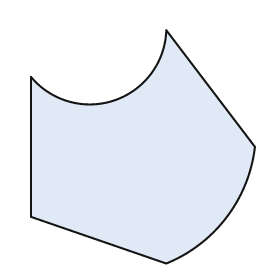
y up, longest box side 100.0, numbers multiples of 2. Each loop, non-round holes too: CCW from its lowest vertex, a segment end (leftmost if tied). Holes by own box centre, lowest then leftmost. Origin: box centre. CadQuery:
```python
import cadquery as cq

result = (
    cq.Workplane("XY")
    .moveTo(10.0, -50.0)
    .threePointArc((36.0, -30.0), (48.0, 0.0))
    .lineTo(10.0, 50.0)
    .threePointArc((-12.0, 20.0), (-48.0, 30.0))
    .lineTo(-48.0, -30.0)
    .close()
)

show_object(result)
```